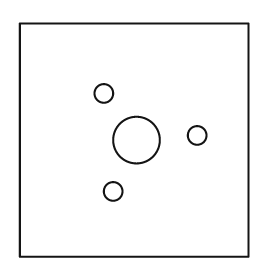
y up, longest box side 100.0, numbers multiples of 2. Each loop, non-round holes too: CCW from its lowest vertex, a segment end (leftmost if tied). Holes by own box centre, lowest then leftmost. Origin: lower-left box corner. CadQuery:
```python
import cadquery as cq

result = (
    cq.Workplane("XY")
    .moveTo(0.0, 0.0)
    .lineTo(98.0, 0.0)
    .lineTo(98.0, 100.0)
    .lineTo(0.0, 100.0)
    .close()
    .moveTo(40.0, 28.0)
    .circle(4.0)
    .moveTo(50.0, 50.0)
    .circle(10.0)
    .moveTo(76.0, 52.0)
    .circle(4.0)
    .moveTo(36.0, 70.0)
    .circle(4.0)
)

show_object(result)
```